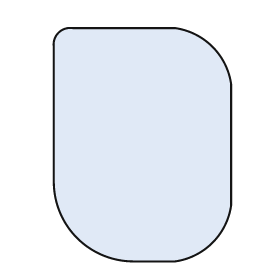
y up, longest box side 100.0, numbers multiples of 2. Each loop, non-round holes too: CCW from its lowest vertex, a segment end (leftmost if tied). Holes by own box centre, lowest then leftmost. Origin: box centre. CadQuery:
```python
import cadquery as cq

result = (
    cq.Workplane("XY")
    .moveTo(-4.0, -50.0)
    .lineTo(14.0, -50.0)
    .threePointArc((30.0, -42.0), (38.0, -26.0))
    .lineTo(38.0, 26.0)
    .threePointArc((30.0, 42.0), (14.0, 50.0))
    .lineTo(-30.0, 50.0)
    .threePointArc((-36.0, 48.0), (-38.0, 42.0))
    .lineTo(-38.0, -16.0)
    .threePointArc((-28.0, -40.0), (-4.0, -50.0))
    .close()
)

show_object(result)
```